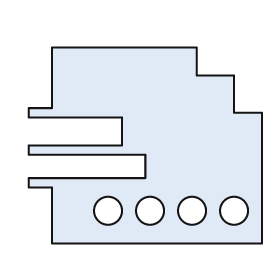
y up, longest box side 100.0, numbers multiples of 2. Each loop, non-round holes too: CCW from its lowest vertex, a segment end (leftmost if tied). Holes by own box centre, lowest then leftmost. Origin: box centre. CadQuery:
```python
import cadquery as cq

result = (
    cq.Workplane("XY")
    .moveTo(-40.0, -42.0)
    .lineTo(50.0, -42.0)
    .lineTo(50.0, 14.0)
    .lineTo(38.0, 14.0)
    .lineTo(38.0, 30.0)
    .lineTo(22.0, 30.0)
    .lineTo(22.0, 42.0)
    .lineTo(-40.0, 42.0)
    .lineTo(-40.0, 16.0)
    .lineTo(-50.0, 16.0)
    .lineTo(-50.0, 12.0)
    .lineTo(-10.0, 12.0)
    .lineTo(-10.0, 0.0)
    .lineTo(-50.0, 0.0)
    .lineTo(-50.0, -4.0)
    .lineTo(0.0, -4.0)
    .lineTo(0.0, -14.0)
    .lineTo(-50.0, -14.0)
    .lineTo(-50.0, -18.0)
    .lineTo(-40.0, -18.0)
    .close()
    .moveTo(-16.0, -28.0)
    .circle(6.0)
    .moveTo(2.0, -28.0)
    .circle(6.0)
    .moveTo(20.0, -28.0)
    .circle(6.0)
    .moveTo(38.0, -28.0)
    .circle(6.0)
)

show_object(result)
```